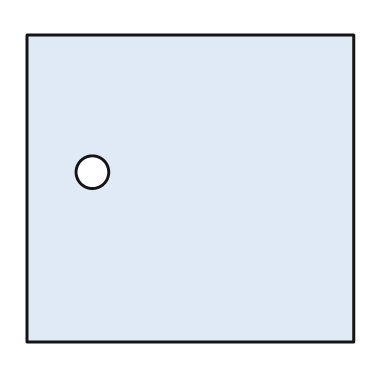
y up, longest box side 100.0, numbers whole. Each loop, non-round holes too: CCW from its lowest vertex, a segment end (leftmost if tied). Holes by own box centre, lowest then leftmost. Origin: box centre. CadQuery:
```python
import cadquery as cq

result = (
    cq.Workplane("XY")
    .moveTo(-50.0, -47.0)
    .lineTo(50.0, -47.0)
    .lineTo(50.0, 47.0)
    .lineTo(-50.0, 47.0)
    .close()
    .moveTo(-30.0, 5.0)
    .circle(5.0)
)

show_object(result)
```